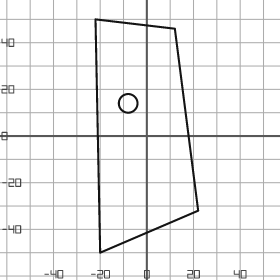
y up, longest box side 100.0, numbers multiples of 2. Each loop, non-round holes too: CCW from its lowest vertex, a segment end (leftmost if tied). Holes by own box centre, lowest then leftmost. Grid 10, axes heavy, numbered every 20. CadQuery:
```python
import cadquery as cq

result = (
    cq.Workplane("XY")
    .moveTo(-20.0, -50.0)
    .lineTo(22.0, -32.0)
    .lineTo(12.0, 46.0)
    .lineTo(-22.0, 50.0)
    .close()
    .moveTo(-8.0, 14.0)
    .circle(4.0)
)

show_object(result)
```